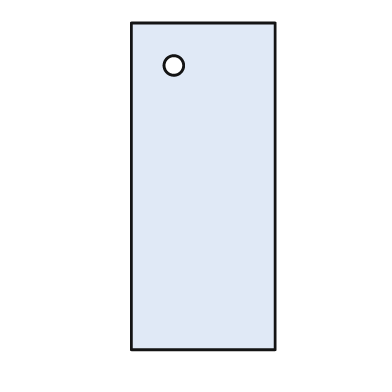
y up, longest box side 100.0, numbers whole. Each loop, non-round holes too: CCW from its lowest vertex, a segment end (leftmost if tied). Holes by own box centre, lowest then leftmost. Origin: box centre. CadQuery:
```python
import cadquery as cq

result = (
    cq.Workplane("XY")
    .moveTo(-22.0, -50.0)
    .lineTo(22.0, -50.0)
    .lineTo(22.0, 50.0)
    .lineTo(-22.0, 50.0)
    .close()
    .moveTo(-9.0, 37.0)
    .circle(3.0)
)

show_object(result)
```